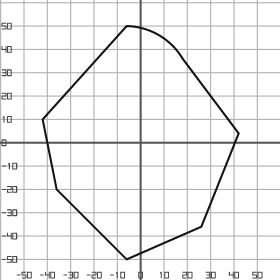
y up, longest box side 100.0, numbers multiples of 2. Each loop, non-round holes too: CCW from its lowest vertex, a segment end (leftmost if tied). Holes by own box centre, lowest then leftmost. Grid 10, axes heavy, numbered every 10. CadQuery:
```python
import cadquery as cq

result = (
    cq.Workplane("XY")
    .moveTo(-6.0, -50.0)
    .lineTo(26.0, -36.0)
    .lineTo(42.0, 4.0)
    .lineTo(18.0, 36.0)
    .threePointArc((8.0, 46.0), (-6.0, 50.0))
    .lineTo(-42.0, 10.0)
    .lineTo(-36.0, -20.0)
    .close()
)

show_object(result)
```